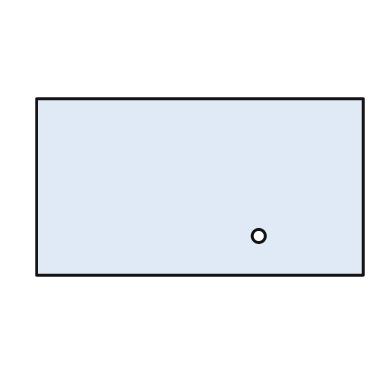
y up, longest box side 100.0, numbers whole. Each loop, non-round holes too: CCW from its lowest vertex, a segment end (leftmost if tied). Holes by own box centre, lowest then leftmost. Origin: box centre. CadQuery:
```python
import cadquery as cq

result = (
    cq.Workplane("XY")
    .moveTo(-50.0, -27.0)
    .lineTo(50.0, -27.0)
    .lineTo(50.0, 27.0)
    .lineTo(-50.0, 27.0)
    .close()
    .moveTo(18.0, -15.0)
    .circle(2.0)
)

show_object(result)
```